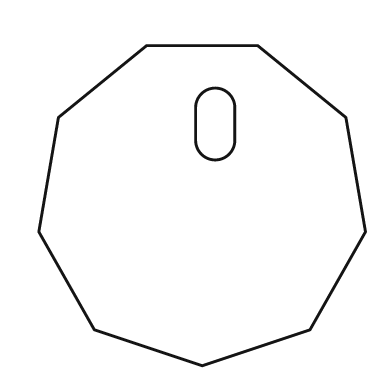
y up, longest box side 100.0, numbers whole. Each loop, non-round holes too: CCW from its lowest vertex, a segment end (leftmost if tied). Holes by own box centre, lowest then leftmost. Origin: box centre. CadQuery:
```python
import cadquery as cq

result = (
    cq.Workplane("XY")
    .moveTo(0.0, -49.0)
    .lineTo(33.0, -38.0)
    .lineTo(50.0, -8.0)
    .lineTo(44.0, 27.0)
    .lineTo(17.0, 49.0)
    .lineTo(-17.0, 49.0)
    .lineTo(-44.0, 27.0)
    .lineTo(-50.0, -8.0)
    .lineTo(-33.0, -38.0)
    .close()
    .moveTo(-2.0, 20.0)
    .threePointArc((4.0, 14.0), (10.0, 20.0))
    .lineTo(10.0, 30.0)
    .threePointArc((4.0, 36.0), (-2.0, 30.0))
    .close()
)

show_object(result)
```